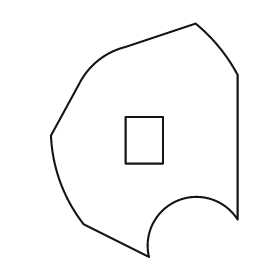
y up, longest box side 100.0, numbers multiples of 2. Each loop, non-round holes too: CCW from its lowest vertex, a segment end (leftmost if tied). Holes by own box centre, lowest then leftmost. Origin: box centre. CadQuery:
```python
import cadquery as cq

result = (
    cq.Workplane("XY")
    .moveTo(2.0, -50.0)
    .threePointArc((14.0, -26.0), (40.0, -34.0))
    .lineTo(40.0, 28.0)
    .threePointArc((32.0, 40.0), (22.0, 50.0))
    .lineTo(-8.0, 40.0)
    .threePointArc((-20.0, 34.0), (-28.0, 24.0))
    .lineTo(-40.0, 2.0)
    .threePointArc((-36.0, -18.0), (-26.0, -36.0))
    .close()
    .moveTo(-8.0, -10.0)
    .lineTo(8.0, -10.0)
    .lineTo(8.0, 10.0)
    .lineTo(-8.0, 10.0)
    .close()
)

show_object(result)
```